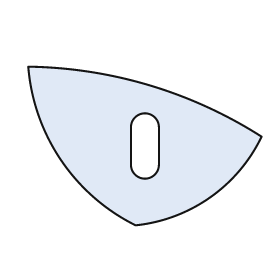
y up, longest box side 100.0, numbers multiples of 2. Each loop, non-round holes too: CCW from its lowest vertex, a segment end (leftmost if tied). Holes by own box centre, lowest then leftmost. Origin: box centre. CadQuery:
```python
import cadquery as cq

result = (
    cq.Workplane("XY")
    .moveTo(-4.0, -34.0)
    .threePointArc((28.0, -22.0), (50.0, 4.0))
    .threePointArc((2.0, 26.0), (-50.0, 34.0))
    .threePointArc((-36.0, -6.0), (-4.0, -34.0))
    .close()
    .moveTo(-6.0, -8.0)
    .threePointArc((0.0, -14.0), (6.0, -8.0))
    .lineTo(6.0, 8.0)
    .threePointArc((0.0, 14.0), (-6.0, 8.0))
    .close()
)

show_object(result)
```